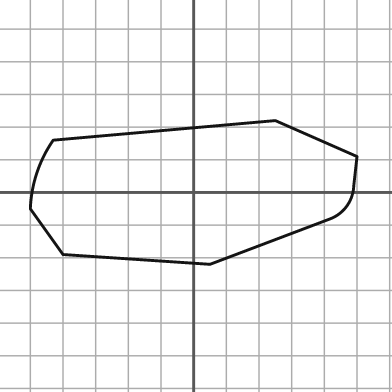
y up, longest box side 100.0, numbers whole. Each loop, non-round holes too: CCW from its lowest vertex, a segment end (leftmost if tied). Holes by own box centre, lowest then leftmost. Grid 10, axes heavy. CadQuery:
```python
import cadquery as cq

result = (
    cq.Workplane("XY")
    .moveTo(5.0, -22.0)
    .lineTo(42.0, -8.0)
    .threePointArc((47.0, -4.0), (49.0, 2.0))
    .lineTo(50.0, 11.0)
    .lineTo(25.0, 22.0)
    .lineTo(-43.0, 16.0)
    .threePointArc((-48.0, 6.0), (-50.0, -5.0))
    .lineTo(-40.0, -19.0)
    .close()
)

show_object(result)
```